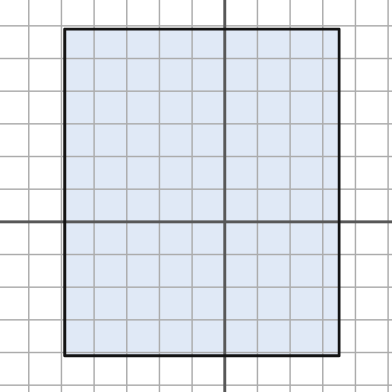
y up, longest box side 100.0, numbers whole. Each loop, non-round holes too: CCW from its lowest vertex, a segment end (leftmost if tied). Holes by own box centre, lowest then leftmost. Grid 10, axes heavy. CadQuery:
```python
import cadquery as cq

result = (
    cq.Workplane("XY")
    .moveTo(-49.0, -41.0)
    .lineTo(35.0, -41.0)
    .lineTo(35.0, 59.0)
    .lineTo(-49.0, 59.0)
    .close()
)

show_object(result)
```